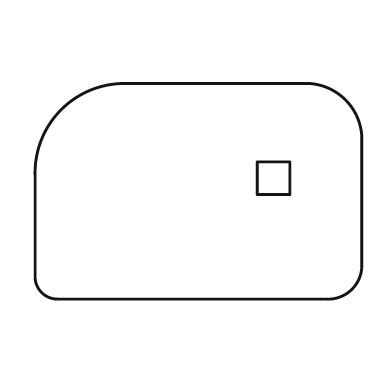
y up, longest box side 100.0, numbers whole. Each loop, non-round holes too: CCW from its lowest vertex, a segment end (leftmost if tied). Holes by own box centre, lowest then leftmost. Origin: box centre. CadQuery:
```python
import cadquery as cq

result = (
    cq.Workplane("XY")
    .moveTo(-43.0, -33.0)
    .lineTo(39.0, -33.0)
    .threePointArc((47.0, -30.0), (50.0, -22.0))
    .lineTo(50.0, 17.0)
    .threePointArc((45.0, 28.0), (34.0, 33.0))
    .lineTo(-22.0, 33.0)
    .threePointArc((-42.0, 25.0), (-50.0, 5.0))
    .lineTo(-50.0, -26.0)
    .threePointArc((-48.0, -31.0), (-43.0, -33.0))
    .close()
    .moveTo(18.0, -1.0)
    .lineTo(28.0, -1.0)
    .lineTo(28.0, 9.0)
    .lineTo(18.0, 9.0)
    .close()
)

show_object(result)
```